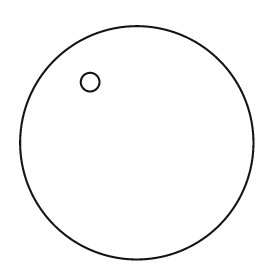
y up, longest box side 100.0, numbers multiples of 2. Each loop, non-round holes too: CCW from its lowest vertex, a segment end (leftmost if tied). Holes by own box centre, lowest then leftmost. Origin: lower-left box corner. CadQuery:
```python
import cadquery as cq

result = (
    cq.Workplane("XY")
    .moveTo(50.0, 50.0)
    .circle(50.0)
    .moveTo(30.0, 76.0)
    .circle(4.0)
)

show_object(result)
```